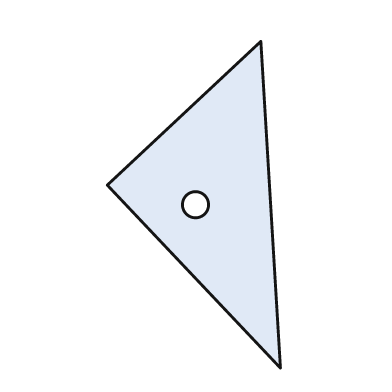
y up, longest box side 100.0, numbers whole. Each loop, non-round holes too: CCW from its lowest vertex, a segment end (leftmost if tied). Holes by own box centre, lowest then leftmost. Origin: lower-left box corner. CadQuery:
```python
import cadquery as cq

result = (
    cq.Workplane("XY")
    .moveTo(53.0, 0.0)
    .lineTo(47.0, 100.0)
    .lineTo(0.0, 56.0)
    .close()
    .moveTo(27.0, 50.0)
    .circle(4.0)
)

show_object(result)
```